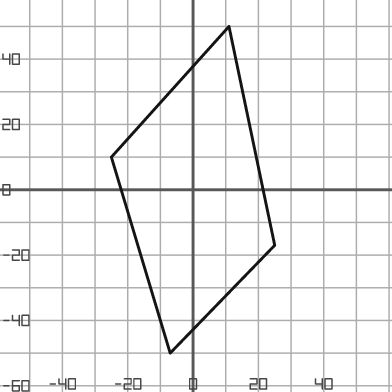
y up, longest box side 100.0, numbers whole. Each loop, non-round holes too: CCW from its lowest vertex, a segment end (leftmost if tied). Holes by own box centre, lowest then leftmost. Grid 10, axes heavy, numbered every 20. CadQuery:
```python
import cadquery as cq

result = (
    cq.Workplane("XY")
    .moveTo(-7.0, -50.0)
    .lineTo(25.0, -17.0)
    .lineTo(11.0, 50.0)
    .lineTo(-25.0, 10.0)
    .close()
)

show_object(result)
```